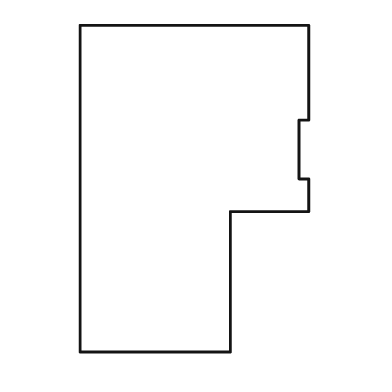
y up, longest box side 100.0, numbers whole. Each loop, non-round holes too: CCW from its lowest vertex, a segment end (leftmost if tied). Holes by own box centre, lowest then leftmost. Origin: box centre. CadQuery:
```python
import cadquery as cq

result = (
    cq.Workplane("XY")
    .moveTo(-35.0, -50.0)
    .lineTo(11.0, -50.0)
    .lineTo(11.0, -7.0)
    .lineTo(35.0, -7.0)
    .lineTo(35.0, 3.0)
    .lineTo(32.0, 3.0)
    .lineTo(32.0, 21.0)
    .lineTo(35.0, 21.0)
    .lineTo(35.0, 50.0)
    .lineTo(-35.0, 50.0)
    .close()
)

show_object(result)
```